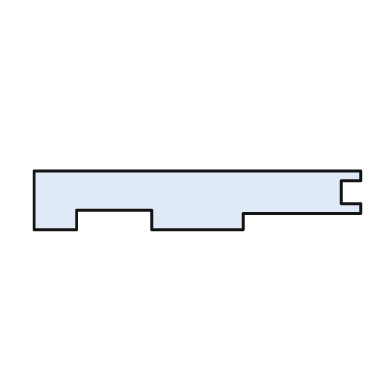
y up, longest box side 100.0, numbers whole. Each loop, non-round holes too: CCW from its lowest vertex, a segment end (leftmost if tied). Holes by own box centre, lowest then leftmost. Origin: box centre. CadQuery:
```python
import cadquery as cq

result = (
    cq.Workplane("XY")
    .moveTo(-50.0, -9.0)
    .lineTo(-37.0, -9.0)
    .lineTo(-37.0, -3.0)
    .lineTo(-14.0, -3.0)
    .lineTo(-14.0, -9.0)
    .lineTo(14.0, -9.0)
    .lineTo(14.0, -4.0)
    .lineTo(50.0, -4.0)
    .lineTo(50.0, -1.0)
    .lineTo(44.0, -1.0)
    .lineTo(44.0, 6.0)
    .lineTo(50.0, 6.0)
    .lineTo(50.0, 9.0)
    .lineTo(-50.0, 9.0)
    .close()
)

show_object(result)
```